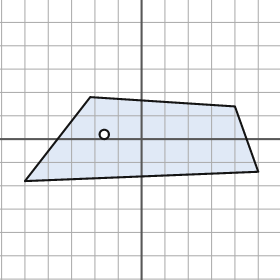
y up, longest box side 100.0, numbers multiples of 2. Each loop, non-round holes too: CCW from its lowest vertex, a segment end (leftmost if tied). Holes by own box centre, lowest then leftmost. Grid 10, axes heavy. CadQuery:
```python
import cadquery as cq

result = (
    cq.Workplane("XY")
    .moveTo(-50.0, -18.0)
    .lineTo(50.0, -14.0)
    .lineTo(40.0, 14.0)
    .lineTo(-22.0, 18.0)
    .close()
    .moveTo(-16.0, 2.0)
    .circle(2.0)
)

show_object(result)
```